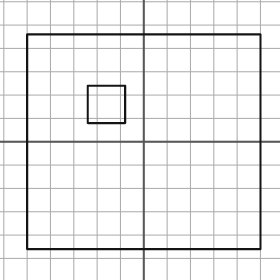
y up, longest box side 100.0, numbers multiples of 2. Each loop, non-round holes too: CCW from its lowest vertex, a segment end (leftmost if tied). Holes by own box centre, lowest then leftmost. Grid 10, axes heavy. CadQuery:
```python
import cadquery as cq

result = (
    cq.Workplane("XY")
    .moveTo(-50.0, -46.0)
    .lineTo(50.0, -46.0)
    .lineTo(50.0, 46.0)
    .lineTo(-50.0, 46.0)
    .close()
    .moveTo(-24.0, 8.0)
    .lineTo(-8.0, 8.0)
    .lineTo(-8.0, 24.0)
    .lineTo(-24.0, 24.0)
    .close()
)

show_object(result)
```